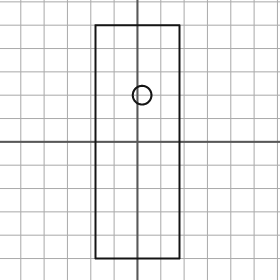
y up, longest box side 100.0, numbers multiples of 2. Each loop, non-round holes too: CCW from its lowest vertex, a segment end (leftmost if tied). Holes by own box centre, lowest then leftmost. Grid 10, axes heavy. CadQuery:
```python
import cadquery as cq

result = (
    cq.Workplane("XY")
    .moveTo(-18.0, -50.0)
    .lineTo(18.0, -50.0)
    .lineTo(18.0, 50.0)
    .lineTo(-18.0, 50.0)
    .close()
    .moveTo(2.0, 20.0)
    .circle(4.0)
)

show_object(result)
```